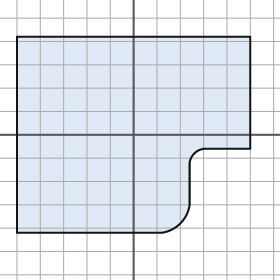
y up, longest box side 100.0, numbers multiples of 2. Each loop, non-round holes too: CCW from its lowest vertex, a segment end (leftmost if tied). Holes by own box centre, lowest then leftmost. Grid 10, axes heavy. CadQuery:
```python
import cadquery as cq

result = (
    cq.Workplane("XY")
    .moveTo(-50.0, -42.0)
    .lineTo(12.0, -42.0)
    .threePointArc((20.0, -38.0), (24.0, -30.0))
    .lineTo(24.0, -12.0)
    .threePointArc((26.0, -8.0), (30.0, -6.0))
    .lineTo(50.0, -6.0)
    .lineTo(50.0, 42.0)
    .lineTo(-50.0, 42.0)
    .close()
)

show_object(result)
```